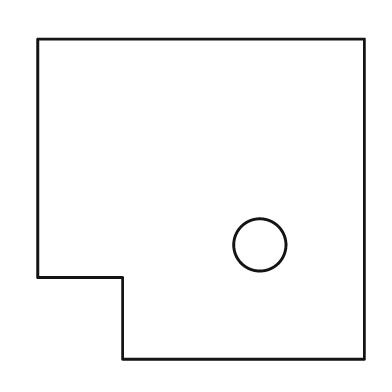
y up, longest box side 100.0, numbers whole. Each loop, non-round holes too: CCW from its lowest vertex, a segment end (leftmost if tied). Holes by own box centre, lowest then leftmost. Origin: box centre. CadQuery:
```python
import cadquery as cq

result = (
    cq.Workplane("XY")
    .moveTo(-24.0, -49.0)
    .lineTo(50.0, -49.0)
    .lineTo(50.0, 49.0)
    .lineTo(-50.0, 49.0)
    .lineTo(-50.0, -24.0)
    .lineTo(-24.0, -24.0)
    .close()
    .moveTo(18.0, -14.0)
    .circle(8.0)
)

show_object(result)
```